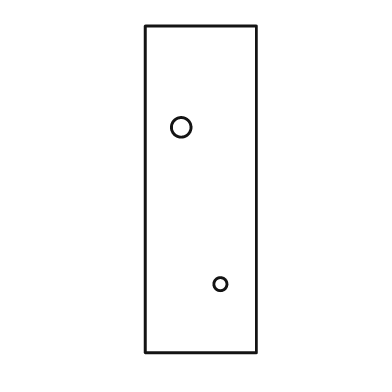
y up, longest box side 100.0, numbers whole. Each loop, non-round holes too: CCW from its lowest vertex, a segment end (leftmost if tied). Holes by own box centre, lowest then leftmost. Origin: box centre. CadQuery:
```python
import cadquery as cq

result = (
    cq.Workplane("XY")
    .moveTo(-17.0, -50.0)
    .lineTo(17.0, -50.0)
    .lineTo(17.0, 50.0)
    .lineTo(-17.0, 50.0)
    .close()
    .moveTo(6.0, -29.0)
    .circle(2.0)
    .moveTo(-6.0, 19.0)
    .circle(3.0)
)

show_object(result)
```